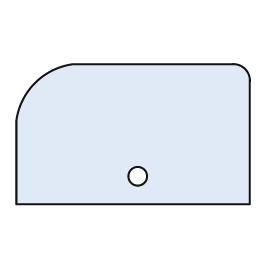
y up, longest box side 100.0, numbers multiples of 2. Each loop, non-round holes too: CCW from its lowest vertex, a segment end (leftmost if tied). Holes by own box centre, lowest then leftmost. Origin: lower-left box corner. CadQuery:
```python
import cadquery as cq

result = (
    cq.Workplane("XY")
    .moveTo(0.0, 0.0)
    .lineTo(100.0, 0.0)
    .lineTo(100.0, 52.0)
    .threePointArc((98.0, 58.0), (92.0, 60.0))
    .lineTo(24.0, 60.0)
    .threePointArc((8.0, 52.0), (0.0, 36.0))
    .close()
    .moveTo(52.0, 12.0)
    .circle(4.0)
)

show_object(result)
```